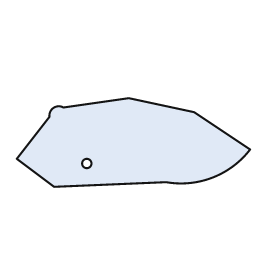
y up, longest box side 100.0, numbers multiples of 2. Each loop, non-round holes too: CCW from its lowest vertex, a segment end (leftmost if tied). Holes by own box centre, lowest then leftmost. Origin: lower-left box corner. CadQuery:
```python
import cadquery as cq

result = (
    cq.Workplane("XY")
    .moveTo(16.0, 0.0)
    .lineTo(64.0, 2.0)
    .threePointArc((84.0, 4.0), (100.0, 16.0))
    .lineTo(76.0, 32.0)
    .lineTo(48.0, 38.0)
    .lineTo(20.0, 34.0)
    .threePointArc((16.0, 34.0), (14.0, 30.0))
    .lineTo(0.0, 12.0)
    .close()
    .moveTo(30.0, 10.0)
    .circle(2.0)
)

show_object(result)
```